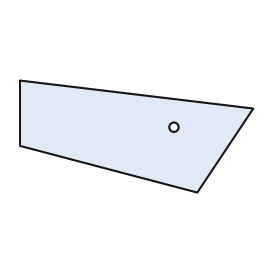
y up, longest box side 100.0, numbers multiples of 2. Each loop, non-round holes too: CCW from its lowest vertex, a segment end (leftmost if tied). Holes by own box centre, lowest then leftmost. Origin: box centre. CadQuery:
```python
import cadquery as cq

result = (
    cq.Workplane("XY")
    .moveTo(26.0, -24.0)
    .lineTo(50.0, 12.0)
    .lineTo(-50.0, 24.0)
    .lineTo(-50.0, -4.0)
    .close()
    .moveTo(16.0, 4.0)
    .circle(2.0)
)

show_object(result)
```